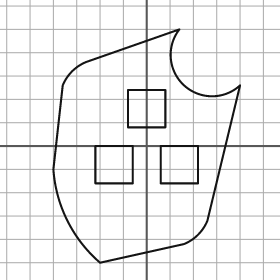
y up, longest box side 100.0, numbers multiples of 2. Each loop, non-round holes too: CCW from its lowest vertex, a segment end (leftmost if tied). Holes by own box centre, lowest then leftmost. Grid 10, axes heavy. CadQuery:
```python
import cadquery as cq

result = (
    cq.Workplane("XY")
    .moveTo(-20.0, -50.0)
    .lineTo(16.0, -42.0)
    .threePointArc((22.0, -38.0), (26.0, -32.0))
    .lineTo(40.0, 26.0)
    .threePointArc((16.0, 26.0), (14.0, 50.0))
    .lineTo(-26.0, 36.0)
    .threePointArc((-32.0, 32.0), (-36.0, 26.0))
    .lineTo(-40.0, -10.0)
    .threePointArc((-34.0, -32.0), (-20.0, -50.0))
    .close()
    .moveTo(-22.0, -16.0)
    .lineTo(-6.0, -16.0)
    .lineTo(-6.0, 0.0)
    .lineTo(-22.0, 0.0)
    .close()
    .moveTo(6.0, -16.0)
    .lineTo(22.0, -16.0)
    .lineTo(22.0, 0.0)
    .lineTo(6.0, 0.0)
    .close()
    .moveTo(-8.0, 8.0)
    .lineTo(8.0, 8.0)
    .lineTo(8.0, 24.0)
    .lineTo(-8.0, 24.0)
    .close()
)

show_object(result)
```